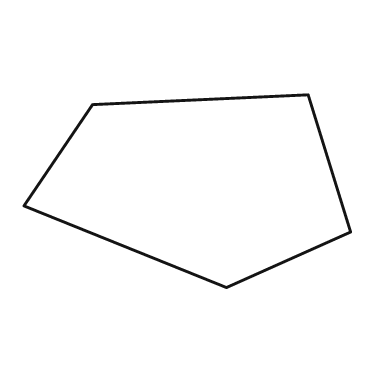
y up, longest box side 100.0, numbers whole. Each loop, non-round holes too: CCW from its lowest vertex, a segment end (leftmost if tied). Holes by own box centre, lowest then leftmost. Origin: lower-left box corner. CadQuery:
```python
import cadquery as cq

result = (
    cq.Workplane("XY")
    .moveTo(62.0, 0.0)
    .lineTo(100.0, 17.0)
    .lineTo(87.0, 59.0)
    .lineTo(21.0, 56.0)
    .lineTo(0.0, 25.0)
    .close()
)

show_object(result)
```